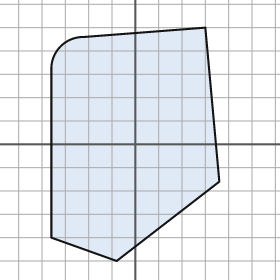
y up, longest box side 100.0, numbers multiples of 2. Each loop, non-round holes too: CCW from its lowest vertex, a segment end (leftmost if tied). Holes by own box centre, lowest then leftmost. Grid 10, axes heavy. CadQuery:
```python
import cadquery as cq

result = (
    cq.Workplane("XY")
    .moveTo(-8.0, -50.0)
    .lineTo(36.0, -16.0)
    .lineTo(30.0, 50.0)
    .lineTo(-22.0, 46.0)
    .threePointArc((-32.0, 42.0), (-36.0, 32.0))
    .lineTo(-36.0, -40.0)
    .close()
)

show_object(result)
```